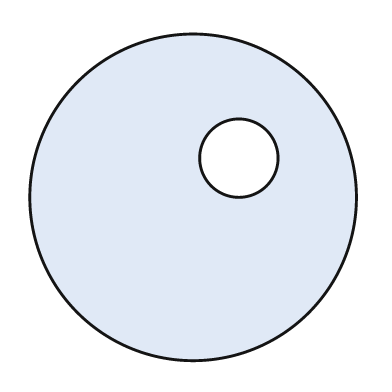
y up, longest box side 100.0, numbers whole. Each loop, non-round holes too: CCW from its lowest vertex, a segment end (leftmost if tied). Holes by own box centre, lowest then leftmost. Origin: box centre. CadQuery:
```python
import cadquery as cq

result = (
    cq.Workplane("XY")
    .moveTo(0.0, 0.0)
    .circle(50.0)
    .moveTo(14.0, 12.0)
    .circle(12.0)
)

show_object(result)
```